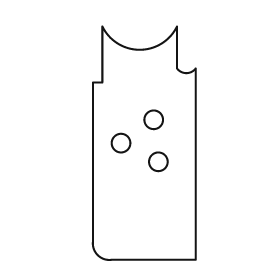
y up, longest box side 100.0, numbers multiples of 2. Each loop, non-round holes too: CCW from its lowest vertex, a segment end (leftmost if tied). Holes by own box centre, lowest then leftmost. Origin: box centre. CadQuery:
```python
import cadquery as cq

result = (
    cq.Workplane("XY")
    .moveTo(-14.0, -50.0)
    .lineTo(22.0, -50.0)
    .lineTo(22.0, 32.0)
    .threePointArc((18.0, 30.0), (14.0, 32.0))
    .lineTo(14.0, 50.0)
    .threePointArc((-2.0, 40.0), (-18.0, 50.0))
    .lineTo(-18.0, 26.0)
    .lineTo(-22.0, 26.0)
    .lineTo(-22.0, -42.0)
    .threePointArc((-20.0, -48.0), (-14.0, -50.0))
    .close()
    .moveTo(6.0, -8.0)
    .circle(4.0)
    .moveTo(-10.0, 0.0)
    .circle(4.0)
    .moveTo(4.0, 10.0)
    .circle(4.0)
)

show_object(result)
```